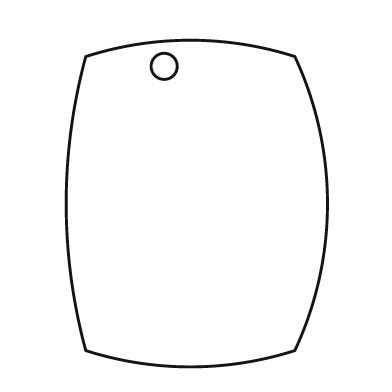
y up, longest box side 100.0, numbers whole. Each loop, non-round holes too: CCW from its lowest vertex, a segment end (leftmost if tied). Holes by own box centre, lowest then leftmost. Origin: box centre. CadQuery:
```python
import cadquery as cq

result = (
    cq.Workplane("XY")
    .moveTo(-34.0, -45.0)
    .threePointArc((-2.0, -50.0), (30.0, -45.0))
    .threePointArc((40.0, 0.0), (30.0, 45.0))
    .threePointArc((-2.0, 50.0), (-34.0, 45.0))
    .threePointArc((-40.0, 0.0), (-34.0, -45.0))
    .close()
    .moveTo(-10.0, 42.0)
    .circle(4.0)
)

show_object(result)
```